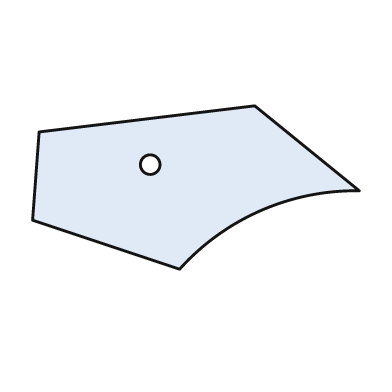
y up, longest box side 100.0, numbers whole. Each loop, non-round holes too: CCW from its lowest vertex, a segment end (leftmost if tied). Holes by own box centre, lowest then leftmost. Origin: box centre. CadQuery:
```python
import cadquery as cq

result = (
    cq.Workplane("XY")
    .moveTo(-5.0, -25.0)
    .threePointArc((20.0, -7.0), (50.0, -1.0))
    .lineTo(18.0, 25.0)
    .lineTo(-48.0, 17.0)
    .lineTo(-50.0, -10.0)
    .close()
    .moveTo(-14.0, 7.0)
    .circle(3.0)
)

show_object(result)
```